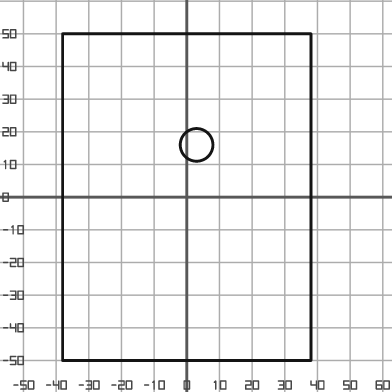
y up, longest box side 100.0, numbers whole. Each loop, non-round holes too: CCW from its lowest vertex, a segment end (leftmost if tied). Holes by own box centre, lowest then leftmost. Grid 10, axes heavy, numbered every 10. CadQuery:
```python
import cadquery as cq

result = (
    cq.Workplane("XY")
    .moveTo(-38.0, -50.0)
    .lineTo(38.0, -50.0)
    .lineTo(38.0, 50.0)
    .lineTo(-38.0, 50.0)
    .close()
    .moveTo(3.0, 16.0)
    .circle(5.0)
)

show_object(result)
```